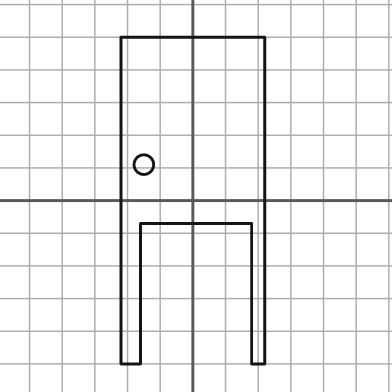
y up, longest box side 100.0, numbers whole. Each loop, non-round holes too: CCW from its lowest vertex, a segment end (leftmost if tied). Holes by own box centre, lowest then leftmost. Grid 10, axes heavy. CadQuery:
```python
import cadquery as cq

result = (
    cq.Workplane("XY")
    .moveTo(-22.0, -50.0)
    .lineTo(-16.0, -50.0)
    .lineTo(-16.0, -7.0)
    .lineTo(18.0, -7.0)
    .lineTo(18.0, -50.0)
    .lineTo(22.0, -50.0)
    .lineTo(22.0, 50.0)
    .lineTo(-22.0, 50.0)
    .close()
    .moveTo(-15.0, 11.0)
    .circle(3.0)
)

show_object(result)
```